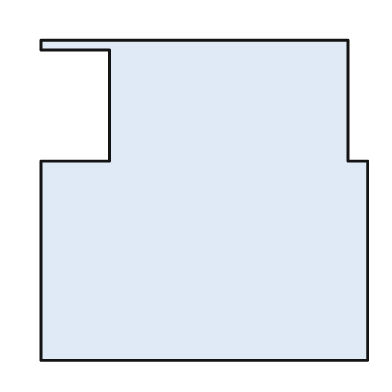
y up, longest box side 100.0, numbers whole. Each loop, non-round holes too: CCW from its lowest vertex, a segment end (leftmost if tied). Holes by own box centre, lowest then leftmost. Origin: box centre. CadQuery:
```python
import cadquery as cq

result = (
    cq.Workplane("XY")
    .moveTo(-50.0, -49.0)
    .lineTo(50.0, -49.0)
    .lineTo(50.0, 12.0)
    .lineTo(44.0, 12.0)
    .lineTo(44.0, 49.0)
    .lineTo(-50.0, 49.0)
    .lineTo(-50.0, 46.0)
    .lineTo(-29.0, 46.0)
    .lineTo(-29.0, 12.0)
    .lineTo(-50.0, 12.0)
    .close()
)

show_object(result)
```